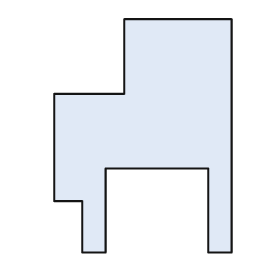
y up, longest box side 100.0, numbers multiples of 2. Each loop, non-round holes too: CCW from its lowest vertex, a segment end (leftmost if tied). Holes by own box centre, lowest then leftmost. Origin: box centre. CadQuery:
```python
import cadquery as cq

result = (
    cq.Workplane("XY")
    .moveTo(-26.0, -50.0)
    .lineTo(-16.0, -50.0)
    .lineTo(-16.0, -14.0)
    .lineTo(28.0, -14.0)
    .lineTo(28.0, -50.0)
    .lineTo(38.0, -50.0)
    .lineTo(38.0, 50.0)
    .lineTo(-8.0, 50.0)
    .lineTo(-8.0, 18.0)
    .lineTo(-38.0, 18.0)
    .lineTo(-38.0, -28.0)
    .lineTo(-26.0, -28.0)
    .close()
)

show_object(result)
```